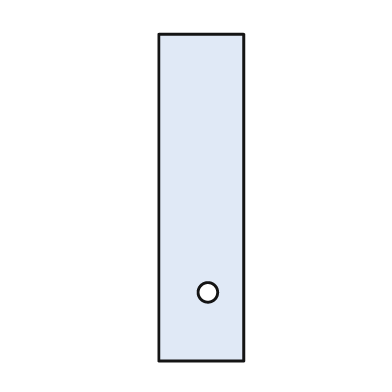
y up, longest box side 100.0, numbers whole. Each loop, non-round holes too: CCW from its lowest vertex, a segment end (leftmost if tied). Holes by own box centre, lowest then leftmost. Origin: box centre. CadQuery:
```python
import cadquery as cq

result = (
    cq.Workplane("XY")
    .moveTo(-13.0, -50.0)
    .lineTo(13.0, -50.0)
    .lineTo(13.0, 50.0)
    .lineTo(-13.0, 50.0)
    .close()
    .moveTo(2.0, -29.0)
    .circle(3.0)
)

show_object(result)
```